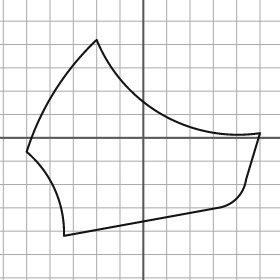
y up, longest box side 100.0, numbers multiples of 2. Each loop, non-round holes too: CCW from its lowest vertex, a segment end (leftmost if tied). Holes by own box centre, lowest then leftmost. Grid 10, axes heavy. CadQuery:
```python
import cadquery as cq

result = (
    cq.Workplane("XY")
    .moveTo(-34.0, -42.0)
    .lineTo(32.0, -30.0)
    .threePointArc((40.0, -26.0), (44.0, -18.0))
    .lineTo(50.0, 2.0)
    .threePointArc((8.0, 10.0), (-20.0, 42.0))
    .threePointArc((-38.0, 20.0), (-50.0, -6.0))
    .threePointArc((-38.0, -22.0), (-34.0, -42.0))
    .close()
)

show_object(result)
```